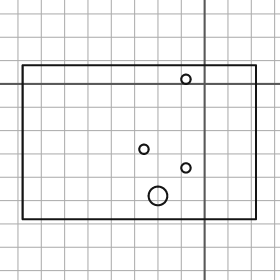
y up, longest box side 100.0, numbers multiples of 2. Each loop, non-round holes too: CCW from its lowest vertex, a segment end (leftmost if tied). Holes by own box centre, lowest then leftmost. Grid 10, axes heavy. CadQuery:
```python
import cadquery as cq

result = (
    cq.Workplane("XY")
    .moveTo(-78.0, -58.0)
    .lineTo(22.0, -58.0)
    .lineTo(22.0, 8.0)
    .lineTo(-78.0, 8.0)
    .close()
    .moveTo(-20.0, -48.0)
    .circle(4.0)
    .moveTo(-8.0, -36.0)
    .circle(2.0)
    .moveTo(-26.0, -28.0)
    .circle(2.0)
    .moveTo(-8.0, 2.0)
    .circle(2.0)
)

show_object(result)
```